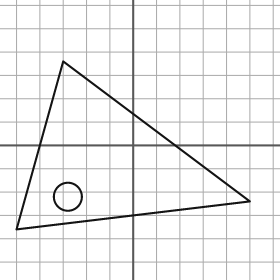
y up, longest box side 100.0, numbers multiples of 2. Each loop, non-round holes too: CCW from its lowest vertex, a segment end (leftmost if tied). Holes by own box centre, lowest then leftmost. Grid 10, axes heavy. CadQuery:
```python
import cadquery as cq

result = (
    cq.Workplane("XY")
    .moveTo(-50.0, -36.0)
    .lineTo(50.0, -24.0)
    .lineTo(-30.0, 36.0)
    .close()
    .moveTo(-28.0, -22.0)
    .circle(6.0)
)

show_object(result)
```